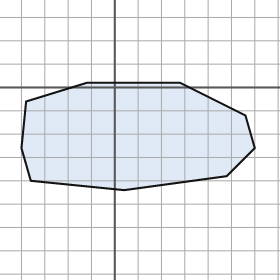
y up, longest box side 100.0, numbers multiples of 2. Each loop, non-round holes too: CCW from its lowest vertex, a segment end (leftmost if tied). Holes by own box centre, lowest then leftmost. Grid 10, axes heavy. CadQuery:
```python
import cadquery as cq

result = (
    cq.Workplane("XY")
    .moveTo(4.0, -44.0)
    .lineTo(48.0, -38.0)
    .lineTo(60.0, -26.0)
    .lineTo(56.0, -12.0)
    .lineTo(28.0, 2.0)
    .lineTo(-12.0, 2.0)
    .lineTo(-38.0, -6.0)
    .lineTo(-40.0, -26.0)
    .lineTo(-36.0, -40.0)
    .close()
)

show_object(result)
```